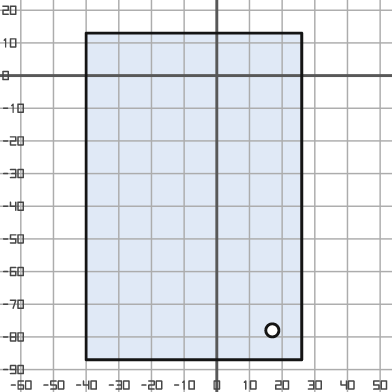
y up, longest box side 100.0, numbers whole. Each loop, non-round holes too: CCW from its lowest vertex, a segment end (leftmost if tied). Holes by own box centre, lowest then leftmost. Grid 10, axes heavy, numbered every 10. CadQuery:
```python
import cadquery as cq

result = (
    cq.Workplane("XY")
    .moveTo(-40.0, -87.0)
    .lineTo(26.0, -87.0)
    .lineTo(26.0, 13.0)
    .lineTo(-40.0, 13.0)
    .close()
    .moveTo(17.0, -78.0)
    .circle(2.0)
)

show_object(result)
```